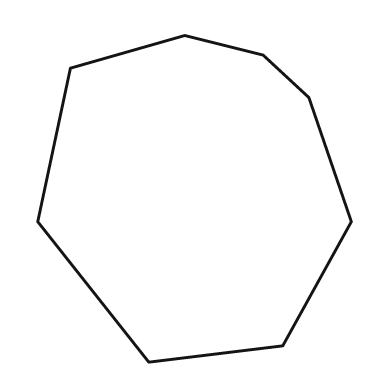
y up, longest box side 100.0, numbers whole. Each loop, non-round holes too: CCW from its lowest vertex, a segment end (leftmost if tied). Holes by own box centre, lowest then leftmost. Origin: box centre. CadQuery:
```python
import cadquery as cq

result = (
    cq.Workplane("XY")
    .moveTo(-14.0, -50.0)
    .lineTo(27.0, -45.0)
    .lineTo(48.0, -7.0)
    .lineTo(35.0, 31.0)
    .lineTo(21.0, 44.0)
    .lineTo(-3.0, 50.0)
    .lineTo(-38.0, 40.0)
    .lineTo(-48.0, -7.0)
    .close()
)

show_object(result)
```